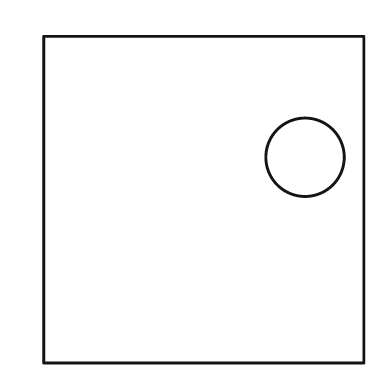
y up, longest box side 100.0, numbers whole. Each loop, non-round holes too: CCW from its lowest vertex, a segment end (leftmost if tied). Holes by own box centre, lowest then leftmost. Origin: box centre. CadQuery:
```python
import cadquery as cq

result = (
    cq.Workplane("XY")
    .moveTo(-49.0, -50.0)
    .lineTo(49.0, -50.0)
    .lineTo(49.0, 50.0)
    .lineTo(-49.0, 50.0)
    .close()
    .moveTo(31.0, 13.0)
    .circle(12.0)
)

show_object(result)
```